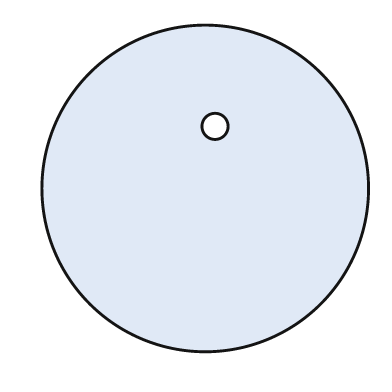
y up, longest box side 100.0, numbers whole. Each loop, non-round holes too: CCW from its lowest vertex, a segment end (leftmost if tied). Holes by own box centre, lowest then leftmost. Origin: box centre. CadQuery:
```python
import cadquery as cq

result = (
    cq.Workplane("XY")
    .moveTo(0.0, 0.0)
    .circle(50.0)
    .moveTo(3.0, 19.0)
    .circle(4.0)
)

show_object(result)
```